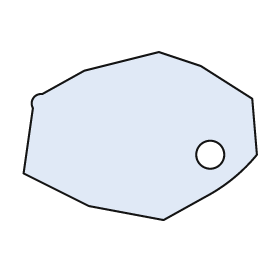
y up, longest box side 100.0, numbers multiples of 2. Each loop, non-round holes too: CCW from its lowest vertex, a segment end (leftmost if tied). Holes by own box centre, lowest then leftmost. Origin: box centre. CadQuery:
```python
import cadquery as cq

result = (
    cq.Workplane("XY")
    .moveTo(10.0, -36.0)
    .lineTo(28.0, -26.0)
    .threePointArc((40.0, -18.0), (50.0, -8.0))
    .lineTo(48.0, 16.0)
    .lineTo(26.0, 30.0)
    .lineTo(8.0, 36.0)
    .lineTo(-24.0, 28.0)
    .lineTo(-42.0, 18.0)
    .threePointArc((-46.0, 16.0), (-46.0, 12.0))
    .lineTo(-50.0, -16.0)
    .lineTo(-22.0, -30.0)
    .close()
    .moveTo(30.0, -8.0)
    .circle(6.0)
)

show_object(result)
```